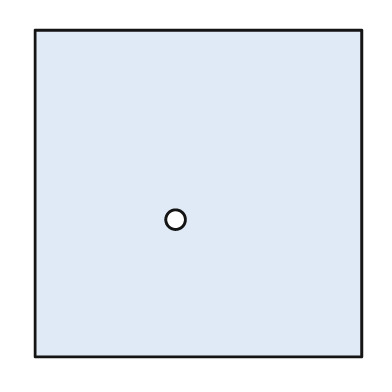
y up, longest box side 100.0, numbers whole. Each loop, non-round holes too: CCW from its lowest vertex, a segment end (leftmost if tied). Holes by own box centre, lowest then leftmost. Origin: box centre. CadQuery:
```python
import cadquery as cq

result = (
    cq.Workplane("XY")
    .moveTo(-50.0, -50.0)
    .lineTo(50.0, -50.0)
    .lineTo(50.0, 50.0)
    .lineTo(-50.0, 50.0)
    .close()
    .moveTo(-7.0, -8.0)
    .circle(3.0)
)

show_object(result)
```